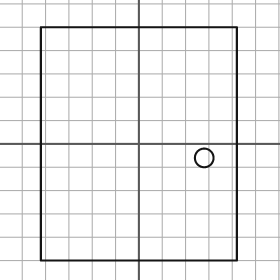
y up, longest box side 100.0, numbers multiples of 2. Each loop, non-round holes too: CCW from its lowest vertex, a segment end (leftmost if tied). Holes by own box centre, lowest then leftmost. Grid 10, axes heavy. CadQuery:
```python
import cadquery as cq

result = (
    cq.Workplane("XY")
    .moveTo(-42.0, -50.0)
    .lineTo(42.0, -50.0)
    .lineTo(42.0, 50.0)
    .lineTo(-42.0, 50.0)
    .close()
    .moveTo(28.0, -6.0)
    .circle(4.0)
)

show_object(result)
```